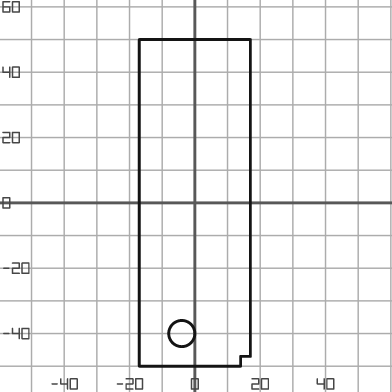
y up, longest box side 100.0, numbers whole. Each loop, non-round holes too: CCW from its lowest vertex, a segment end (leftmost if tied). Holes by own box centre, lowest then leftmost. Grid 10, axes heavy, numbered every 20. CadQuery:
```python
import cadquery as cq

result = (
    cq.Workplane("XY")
    .moveTo(-17.0, -50.0)
    .lineTo(14.0, -50.0)
    .lineTo(14.0, -47.0)
    .lineTo(17.0, -47.0)
    .lineTo(17.0, 50.0)
    .lineTo(-17.0, 50.0)
    .close()
    .moveTo(-4.0, -40.0)
    .circle(4.0)
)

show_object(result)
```